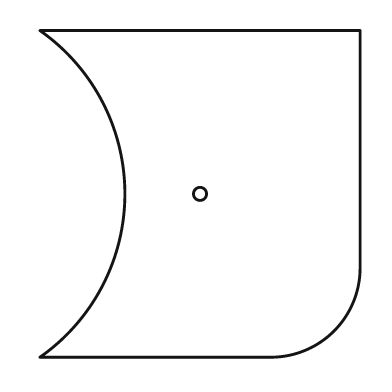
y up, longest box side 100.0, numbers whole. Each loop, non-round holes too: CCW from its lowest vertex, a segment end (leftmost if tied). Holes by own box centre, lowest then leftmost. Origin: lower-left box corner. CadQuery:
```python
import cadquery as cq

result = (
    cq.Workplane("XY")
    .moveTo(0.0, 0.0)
    .lineTo(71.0, 0.0)
    .threePointArc((90.0, 8.0), (98.0, 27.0))
    .lineTo(98.0, 100.0)
    .lineTo(0.0, 100.0)
    .threePointArc((26.0, 50.0), (0.0, 0.0))
    .close()
    .moveTo(49.0, 50.0)
    .circle(2.0)
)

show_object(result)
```